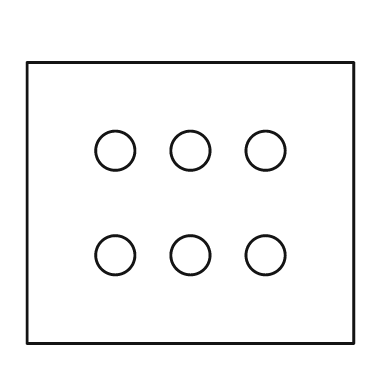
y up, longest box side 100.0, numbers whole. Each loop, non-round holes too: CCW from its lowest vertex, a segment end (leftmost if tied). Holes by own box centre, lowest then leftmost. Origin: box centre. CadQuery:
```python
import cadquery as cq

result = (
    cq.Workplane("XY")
    .moveTo(-50.0, -43.0)
    .lineTo(50.0, -43.0)
    .lineTo(50.0, 43.0)
    .lineTo(-50.0, 43.0)
    .close()
    .moveTo(-23.0, -16.0)
    .circle(6.0)
    .moveTo(0.0, -16.0)
    .circle(6.0)
    .moveTo(23.0, -16.0)
    .circle(6.0)
    .moveTo(-23.0, 16.0)
    .circle(6.0)
    .moveTo(0.0, 16.0)
    .circle(6.0)
    .moveTo(23.0, 16.0)
    .circle(6.0)
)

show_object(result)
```